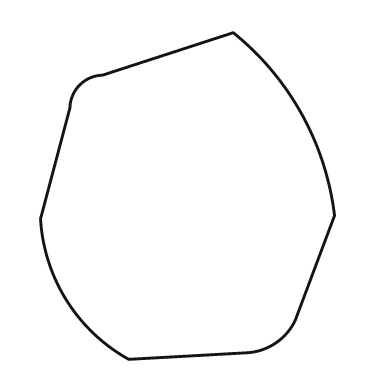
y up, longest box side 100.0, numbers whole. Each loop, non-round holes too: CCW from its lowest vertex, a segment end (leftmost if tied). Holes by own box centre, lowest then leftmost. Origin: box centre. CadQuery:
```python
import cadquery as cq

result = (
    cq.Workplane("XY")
    .moveTo(-18.0, -50.0)
    .lineTo(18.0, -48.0)
    .threePointArc((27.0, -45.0), (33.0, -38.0))
    .lineTo(45.0, -6.0)
    .threePointArc((35.0, 25.0), (14.0, 50.0))
    .lineTo(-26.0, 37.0)
    .threePointArc((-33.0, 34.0), (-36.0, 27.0))
    .lineTo(-45.0, -7.0)
    .threePointArc((-37.0, -32.0), (-18.0, -50.0))
    .close()
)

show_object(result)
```